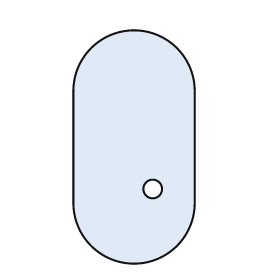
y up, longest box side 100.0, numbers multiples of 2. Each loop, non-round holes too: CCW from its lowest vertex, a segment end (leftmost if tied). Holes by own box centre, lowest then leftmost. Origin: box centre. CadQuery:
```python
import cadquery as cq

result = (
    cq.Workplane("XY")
    .moveTo(-26.0, -24.0)
    .threePointArc((0.0, -50.0), (26.0, -24.0))
    .lineTo(26.0, 24.0)
    .threePointArc((0.0, 50.0), (-26.0, 24.0))
    .close()
    .moveTo(8.0, -18.0)
    .circle(4.0)
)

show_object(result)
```